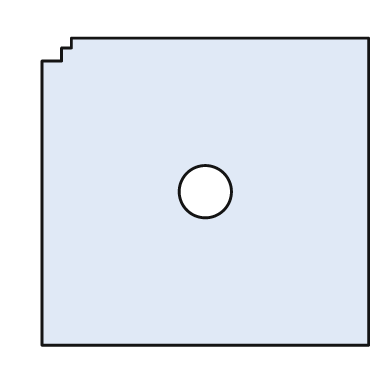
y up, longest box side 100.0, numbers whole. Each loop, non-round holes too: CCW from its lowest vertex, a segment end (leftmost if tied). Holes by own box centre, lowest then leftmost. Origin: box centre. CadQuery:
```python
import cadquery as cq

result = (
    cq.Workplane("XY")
    .moveTo(-50.0, -47.0)
    .lineTo(50.0, -47.0)
    .lineTo(50.0, 47.0)
    .lineTo(-41.0, 47.0)
    .lineTo(-41.0, 44.0)
    .lineTo(-44.0, 44.0)
    .lineTo(-44.0, 40.0)
    .lineTo(-50.0, 40.0)
    .close()
    .moveTo(0.0, 0.0)
    .circle(8.0)
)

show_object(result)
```